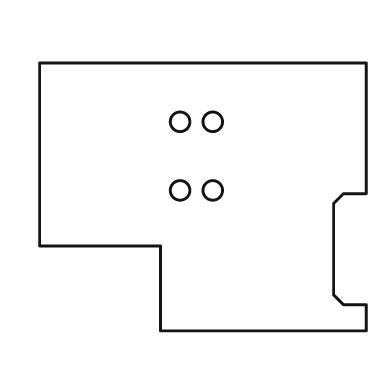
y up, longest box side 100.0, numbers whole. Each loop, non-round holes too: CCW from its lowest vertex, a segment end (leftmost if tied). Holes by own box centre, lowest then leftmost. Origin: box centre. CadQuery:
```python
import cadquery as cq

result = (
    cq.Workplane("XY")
    .moveTo(-13.0, -41.0)
    .lineTo(50.0, -41.0)
    .lineTo(50.0, -33.0)
    .lineTo(43.0, -33.0)
    .lineTo(40.0, -30.0)
    .lineTo(40.0, -2.0)
    .lineTo(43.0, 1.0)
    .lineTo(50.0, 1.0)
    .lineTo(50.0, 41.0)
    .lineTo(-50.0, 41.0)
    .lineTo(-50.0, -15.0)
    .lineTo(-13.0, -15.0)
    .close()
    .moveTo(-7.0, 2.0)
    .circle(3.0)
    .moveTo(3.0, 2.0)
    .circle(3.0)
    .moveTo(-7.0, 23.0)
    .circle(3.0)
    .moveTo(3.0, 23.0)
    .circle(3.0)
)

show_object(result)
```